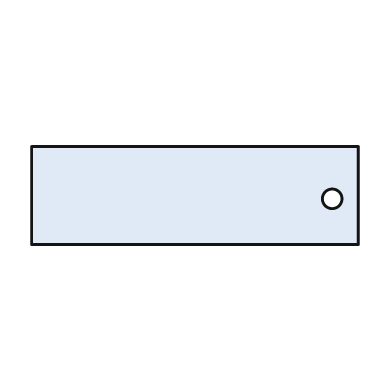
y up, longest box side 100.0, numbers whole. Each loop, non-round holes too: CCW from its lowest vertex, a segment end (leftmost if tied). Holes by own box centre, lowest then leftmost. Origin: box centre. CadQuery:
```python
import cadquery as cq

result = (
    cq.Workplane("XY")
    .moveTo(-50.0, -15.0)
    .lineTo(50.0, -15.0)
    .lineTo(50.0, 15.0)
    .lineTo(-50.0, 15.0)
    .close()
    .moveTo(42.0, -1.0)
    .circle(3.0)
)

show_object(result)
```